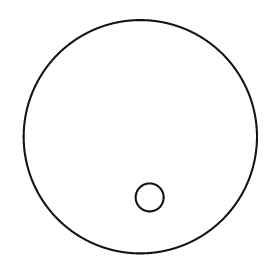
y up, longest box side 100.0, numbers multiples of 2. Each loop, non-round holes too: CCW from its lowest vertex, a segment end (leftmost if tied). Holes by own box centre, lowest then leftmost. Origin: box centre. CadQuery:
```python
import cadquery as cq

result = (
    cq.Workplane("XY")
    .moveTo(0.0, 0.0)
    .circle(50.0)
    .moveTo(4.0, -26.0)
    .circle(6.0)
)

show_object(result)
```